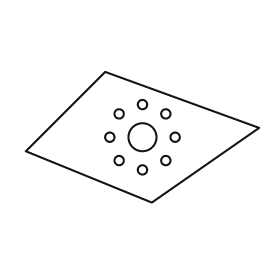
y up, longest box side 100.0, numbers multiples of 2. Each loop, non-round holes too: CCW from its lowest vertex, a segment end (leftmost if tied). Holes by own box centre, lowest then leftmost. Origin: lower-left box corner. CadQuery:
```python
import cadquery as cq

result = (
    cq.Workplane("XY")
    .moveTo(54.0, 0.0)
    .lineTo(100.0, 32.0)
    .lineTo(34.0, 56.0)
    .lineTo(0.0, 22.0)
    .close()
    .moveTo(50.0, 14.0)
    .circle(2.0)
    .moveTo(40.0, 18.0)
    .circle(2.0)
    .moveTo(60.0, 18.0)
    .circle(2.0)
    .moveTo(36.0, 28.0)
    .circle(2.0)
    .moveTo(50.0, 28.0)
    .circle(6.0)
    .moveTo(64.0, 28.0)
    .circle(2.0)
    .moveTo(40.0, 38.0)
    .circle(2.0)
    .moveTo(60.0, 38.0)
    .circle(2.0)
    .moveTo(50.0, 42.0)
    .circle(2.0)
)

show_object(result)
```